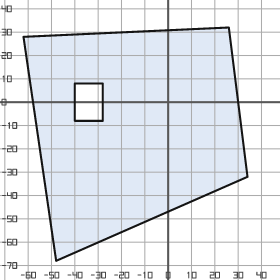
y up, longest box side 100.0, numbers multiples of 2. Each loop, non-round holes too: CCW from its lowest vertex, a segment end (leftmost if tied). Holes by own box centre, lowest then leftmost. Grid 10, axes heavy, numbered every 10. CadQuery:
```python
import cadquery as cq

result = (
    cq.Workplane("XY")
    .moveTo(-48.0, -68.0)
    .lineTo(34.0, -32.0)
    .lineTo(26.0, 32.0)
    .lineTo(-62.0, 28.0)
    .close()
    .moveTo(-40.0, -8.0)
    .lineTo(-28.0, -8.0)
    .lineTo(-28.0, 8.0)
    .lineTo(-40.0, 8.0)
    .close()
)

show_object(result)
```